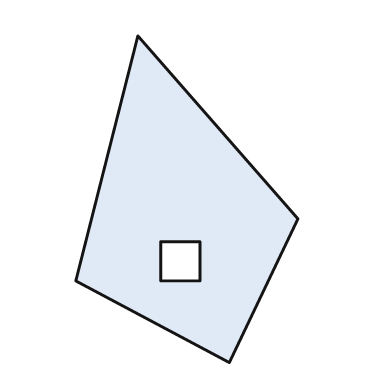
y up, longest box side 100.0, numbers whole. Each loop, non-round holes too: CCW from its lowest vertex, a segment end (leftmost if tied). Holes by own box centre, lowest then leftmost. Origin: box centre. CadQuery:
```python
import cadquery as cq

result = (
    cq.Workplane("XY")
    .moveTo(13.0, -50.0)
    .lineTo(34.0, -6.0)
    .lineTo(-15.0, 50.0)
    .lineTo(-34.0, -25.0)
    .close()
    .moveTo(-8.0, -25.0)
    .lineTo(4.0, -25.0)
    .lineTo(4.0, -13.0)
    .lineTo(-8.0, -13.0)
    .close()
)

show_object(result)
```